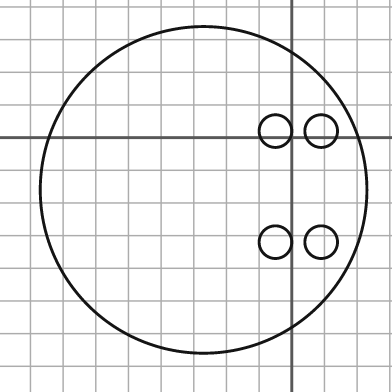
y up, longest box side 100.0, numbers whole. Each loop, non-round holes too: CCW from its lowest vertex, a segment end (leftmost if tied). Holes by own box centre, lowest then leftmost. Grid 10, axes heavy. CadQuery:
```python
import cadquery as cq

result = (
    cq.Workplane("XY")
    .moveTo(-27.0, -16.0)
    .circle(50.0)
    .moveTo(-5.0, -32.0)
    .circle(5.0)
    .moveTo(9.0, -32.0)
    .circle(5.0)
    .moveTo(-5.0, 2.0)
    .circle(5.0)
    .moveTo(9.0, 2.0)
    .circle(5.0)
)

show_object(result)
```